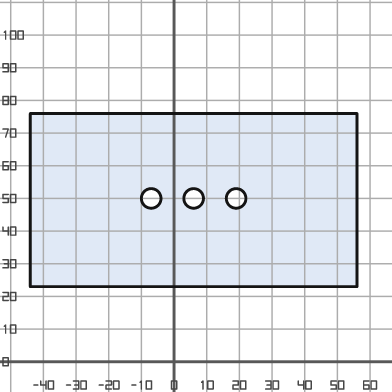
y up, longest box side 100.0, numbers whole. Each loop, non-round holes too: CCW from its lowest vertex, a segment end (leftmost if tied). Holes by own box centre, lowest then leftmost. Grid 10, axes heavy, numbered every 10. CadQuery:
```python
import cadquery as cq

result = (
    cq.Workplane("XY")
    .moveTo(-44.0, 23.0)
    .lineTo(56.0, 23.0)
    .lineTo(56.0, 76.0)
    .lineTo(-44.0, 76.0)
    .close()
    .moveTo(-7.0, 50.0)
    .circle(3.0)
    .moveTo(6.0, 50.0)
    .circle(3.0)
    .moveTo(19.0, 50.0)
    .circle(3.0)
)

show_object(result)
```